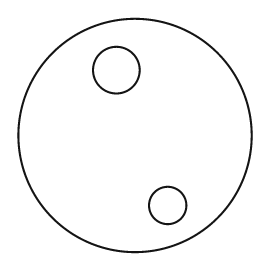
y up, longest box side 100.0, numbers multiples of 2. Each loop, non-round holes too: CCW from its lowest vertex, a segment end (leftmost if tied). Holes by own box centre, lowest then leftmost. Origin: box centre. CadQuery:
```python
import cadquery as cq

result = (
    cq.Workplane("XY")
    .moveTo(0.0, 0.0)
    .circle(50.0)
    .moveTo(14.0, -30.0)
    .circle(8.0)
    .moveTo(-8.0, 28.0)
    .circle(10.0)
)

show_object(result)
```